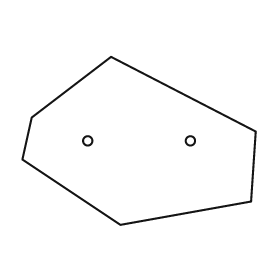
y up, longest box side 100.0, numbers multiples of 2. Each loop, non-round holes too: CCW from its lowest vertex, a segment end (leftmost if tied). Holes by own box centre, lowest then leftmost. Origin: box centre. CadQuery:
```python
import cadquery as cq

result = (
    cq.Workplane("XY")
    .moveTo(-8.0, -36.0)
    .lineTo(48.0, -26.0)
    .lineTo(50.0, 4.0)
    .lineTo(-12.0, 36.0)
    .lineTo(-46.0, 10.0)
    .lineTo(-50.0, -8.0)
    .close()
    .moveTo(-22.0, 0.0)
    .circle(2.0)
    .moveTo(22.0, 0.0)
    .circle(2.0)
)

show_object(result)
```